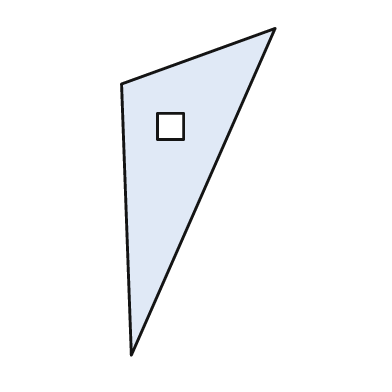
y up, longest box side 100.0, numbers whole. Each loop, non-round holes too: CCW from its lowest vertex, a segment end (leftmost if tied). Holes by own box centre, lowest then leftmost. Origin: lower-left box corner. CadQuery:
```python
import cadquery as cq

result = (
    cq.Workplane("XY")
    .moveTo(3.0, 0.0)
    .lineTo(47.0, 100.0)
    .lineTo(0.0, 83.0)
    .close()
    .moveTo(11.0, 66.0)
    .lineTo(19.0, 66.0)
    .lineTo(19.0, 74.0)
    .lineTo(11.0, 74.0)
    .close()
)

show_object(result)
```